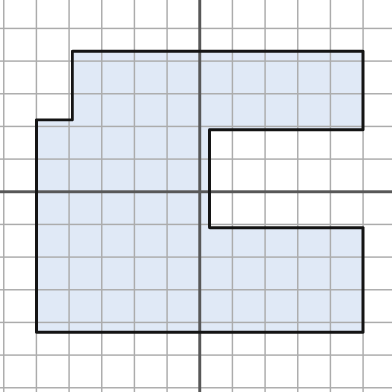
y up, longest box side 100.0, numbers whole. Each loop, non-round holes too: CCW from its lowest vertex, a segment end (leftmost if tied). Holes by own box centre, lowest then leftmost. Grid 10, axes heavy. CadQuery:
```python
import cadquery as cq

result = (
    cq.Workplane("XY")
    .moveTo(-50.0, -43.0)
    .lineTo(50.0, -43.0)
    .lineTo(50.0, -11.0)
    .lineTo(3.0, -11.0)
    .lineTo(3.0, 19.0)
    .lineTo(50.0, 19.0)
    .lineTo(50.0, 43.0)
    .lineTo(-39.0, 43.0)
    .lineTo(-39.0, 22.0)
    .lineTo(-50.0, 22.0)
    .close()
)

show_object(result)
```